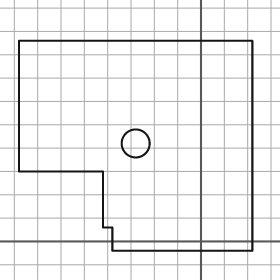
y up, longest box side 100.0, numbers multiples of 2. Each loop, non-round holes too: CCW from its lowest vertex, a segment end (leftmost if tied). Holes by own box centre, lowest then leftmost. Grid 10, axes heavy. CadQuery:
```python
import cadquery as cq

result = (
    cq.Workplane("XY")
    .moveTo(-38.0, -4.0)
    .lineTo(22.0, -4.0)
    .lineTo(22.0, 86.0)
    .lineTo(-78.0, 86.0)
    .lineTo(-78.0, 30.0)
    .lineTo(-42.0, 30.0)
    .lineTo(-42.0, 6.0)
    .lineTo(-38.0, 6.0)
    .close()
    .moveTo(-28.0, 42.0)
    .circle(6.0)
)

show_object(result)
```